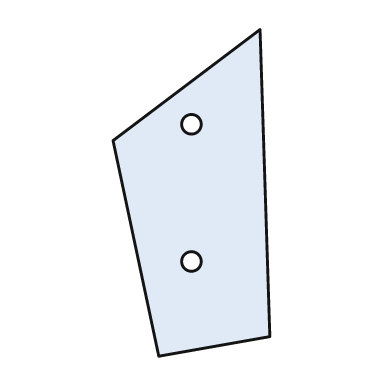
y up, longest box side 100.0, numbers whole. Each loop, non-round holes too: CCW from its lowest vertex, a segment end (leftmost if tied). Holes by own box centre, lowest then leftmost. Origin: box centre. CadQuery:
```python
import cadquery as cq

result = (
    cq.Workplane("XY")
    .moveTo(-10.0, -50.0)
    .lineTo(24.0, -44.0)
    .lineTo(21.0, 50.0)
    .lineTo(-24.0, 16.0)
    .close()
    .moveTo(0.0, -21.0)
    .circle(3.0)
    .moveTo(0.0, 21.0)
    .circle(3.0)
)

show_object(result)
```